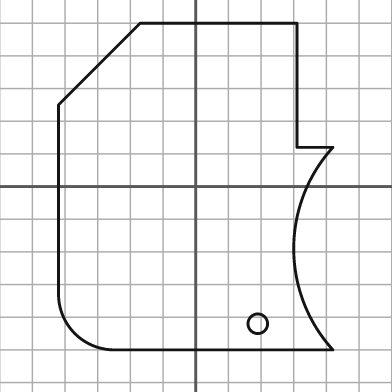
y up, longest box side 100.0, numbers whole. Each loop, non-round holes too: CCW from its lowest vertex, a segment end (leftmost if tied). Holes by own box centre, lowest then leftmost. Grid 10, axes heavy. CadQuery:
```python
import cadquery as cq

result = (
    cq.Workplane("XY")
    .moveTo(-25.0, -50.0)
    .lineTo(42.0, -50.0)
    .threePointArc((30.0, -19.0), (42.0, 12.0))
    .lineTo(31.0, 12.0)
    .lineTo(31.0, 50.0)
    .lineTo(-17.0, 50.0)
    .lineTo(-42.0, 25.0)
    .lineTo(-42.0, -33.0)
    .threePointArc((-37.0, -45.0), (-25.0, -50.0))
    .close()
    .moveTo(19.0, -42.0)
    .circle(3.0)
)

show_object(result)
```